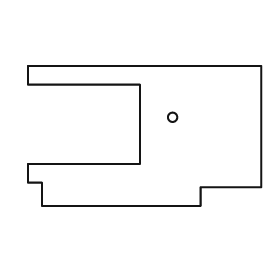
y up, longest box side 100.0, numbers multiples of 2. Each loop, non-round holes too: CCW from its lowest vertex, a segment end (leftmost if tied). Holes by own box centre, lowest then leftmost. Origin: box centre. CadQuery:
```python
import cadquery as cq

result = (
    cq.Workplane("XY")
    .moveTo(-44.0, -30.0)
    .lineTo(24.0, -30.0)
    .lineTo(24.0, -22.0)
    .lineTo(50.0, -22.0)
    .lineTo(50.0, 30.0)
    .lineTo(-50.0, 30.0)
    .lineTo(-50.0, 22.0)
    .lineTo(-2.0, 22.0)
    .lineTo(-2.0, -12.0)
    .lineTo(-50.0, -12.0)
    .lineTo(-50.0, -20.0)
    .lineTo(-44.0, -20.0)
    .close()
    .moveTo(12.0, 8.0)
    .circle(2.0)
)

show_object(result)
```